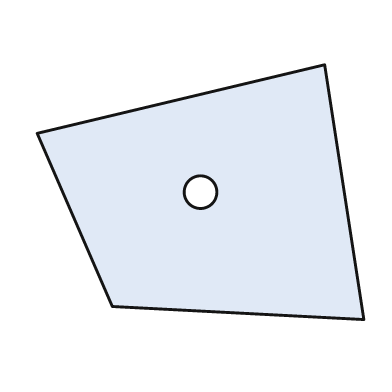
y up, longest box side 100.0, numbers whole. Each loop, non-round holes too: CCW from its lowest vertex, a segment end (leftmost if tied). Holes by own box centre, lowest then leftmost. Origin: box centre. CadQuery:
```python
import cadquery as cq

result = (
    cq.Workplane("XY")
    .moveTo(50.0, -39.0)
    .lineTo(38.0, 39.0)
    .lineTo(-50.0, 18.0)
    .lineTo(-27.0, -35.0)
    .close()
    .moveTo(0.0, 0.0)
    .circle(5.0)
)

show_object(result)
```